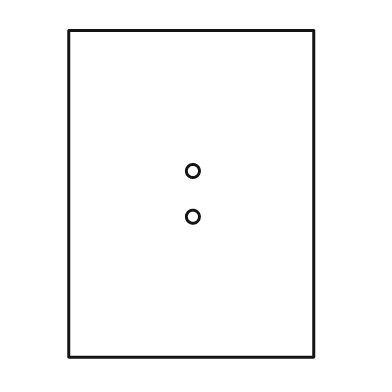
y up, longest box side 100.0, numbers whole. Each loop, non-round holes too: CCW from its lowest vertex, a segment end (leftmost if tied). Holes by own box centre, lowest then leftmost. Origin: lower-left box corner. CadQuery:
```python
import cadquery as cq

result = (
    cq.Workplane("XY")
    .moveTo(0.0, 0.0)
    .lineTo(75.0, 0.0)
    .lineTo(75.0, 100.0)
    .lineTo(0.0, 100.0)
    .close()
    .moveTo(38.0, 43.0)
    .circle(2.0)
    .moveTo(38.0, 57.0)
    .circle(2.0)
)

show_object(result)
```